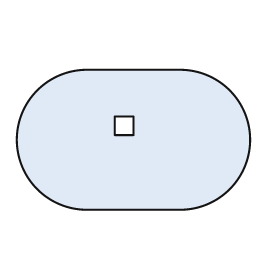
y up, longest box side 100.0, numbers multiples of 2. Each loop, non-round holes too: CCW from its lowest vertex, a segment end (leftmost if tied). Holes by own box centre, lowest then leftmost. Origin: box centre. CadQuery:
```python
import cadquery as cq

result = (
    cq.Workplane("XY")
    .moveTo(-20.0, -30.0)
    .lineTo(20.0, -30.0)
    .threePointArc((50.0, 0.0), (20.0, 30.0))
    .lineTo(-20.0, 30.0)
    .threePointArc((-50.0, 0.0), (-20.0, -30.0))
    .close()
    .moveTo(-8.0, 2.0)
    .lineTo(0.0, 2.0)
    .lineTo(0.0, 10.0)
    .lineTo(-8.0, 10.0)
    .close()
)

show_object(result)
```